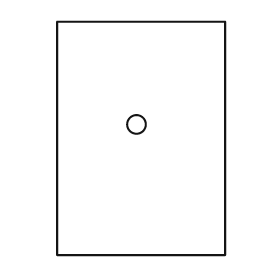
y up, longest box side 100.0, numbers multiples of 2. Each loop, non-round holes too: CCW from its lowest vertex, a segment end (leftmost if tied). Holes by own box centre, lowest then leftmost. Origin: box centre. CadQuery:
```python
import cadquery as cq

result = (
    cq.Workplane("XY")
    .moveTo(-36.0, -50.0)
    .lineTo(36.0, -50.0)
    .lineTo(36.0, 50.0)
    .lineTo(-36.0, 50.0)
    .close()
    .moveTo(-2.0, 6.0)
    .circle(4.0)
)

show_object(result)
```